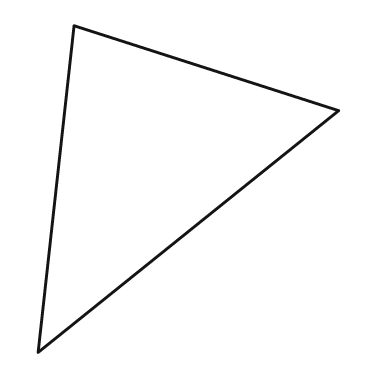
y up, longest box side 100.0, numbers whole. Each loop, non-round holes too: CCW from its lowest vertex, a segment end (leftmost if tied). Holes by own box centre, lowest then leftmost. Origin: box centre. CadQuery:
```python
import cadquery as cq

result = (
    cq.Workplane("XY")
    .moveTo(-46.0, -50.0)
    .lineTo(46.0, 24.0)
    .lineTo(-35.0, 50.0)
    .close()
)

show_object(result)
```